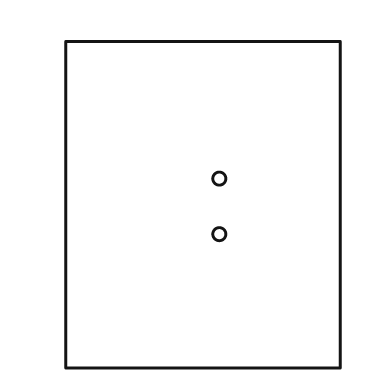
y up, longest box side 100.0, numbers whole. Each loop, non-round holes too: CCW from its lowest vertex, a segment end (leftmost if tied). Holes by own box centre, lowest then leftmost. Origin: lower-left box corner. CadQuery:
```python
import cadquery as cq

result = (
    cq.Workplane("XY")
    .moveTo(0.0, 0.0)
    .lineTo(84.0, 0.0)
    .lineTo(84.0, 100.0)
    .lineTo(0.0, 100.0)
    .close()
    .moveTo(47.0, 41.0)
    .circle(2.0)
    .moveTo(47.0, 58.0)
    .circle(2.0)
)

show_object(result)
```